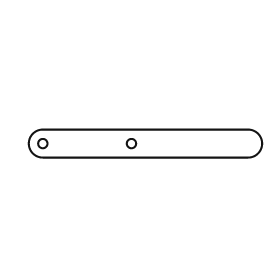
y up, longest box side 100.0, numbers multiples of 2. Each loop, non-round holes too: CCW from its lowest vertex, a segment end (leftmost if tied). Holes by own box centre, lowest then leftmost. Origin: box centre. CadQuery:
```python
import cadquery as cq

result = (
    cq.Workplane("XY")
    .moveTo(-44.0, -6.0)
    .lineTo(44.0, -6.0)
    .threePointArc((50.0, 0.0), (44.0, 6.0))
    .lineTo(-44.0, 6.0)
    .threePointArc((-50.0, 0.0), (-44.0, -6.0))
    .close()
    .moveTo(-44.0, 0.0)
    .circle(2.0)
    .moveTo(-6.0, 0.0)
    .circle(2.0)
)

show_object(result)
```